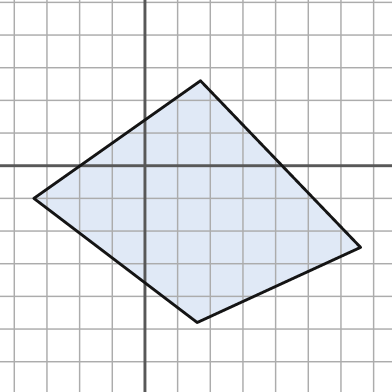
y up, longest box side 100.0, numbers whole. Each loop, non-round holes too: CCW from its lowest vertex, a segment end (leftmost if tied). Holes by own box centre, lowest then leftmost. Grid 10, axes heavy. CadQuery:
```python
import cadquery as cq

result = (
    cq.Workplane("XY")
    .moveTo(16.0, -48.0)
    .lineTo(66.0, -25.0)
    .lineTo(17.0, 26.0)
    .lineTo(-34.0, -10.0)
    .close()
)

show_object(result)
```